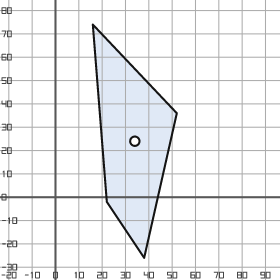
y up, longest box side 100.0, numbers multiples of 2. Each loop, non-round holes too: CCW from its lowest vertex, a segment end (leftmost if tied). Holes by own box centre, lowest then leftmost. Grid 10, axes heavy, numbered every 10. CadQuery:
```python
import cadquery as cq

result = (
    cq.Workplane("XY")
    .moveTo(38.0, -26.0)
    .lineTo(52.0, 36.0)
    .lineTo(16.0, 74.0)
    .lineTo(22.0, -2.0)
    .close()
    .moveTo(34.0, 24.0)
    .circle(2.0)
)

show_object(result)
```